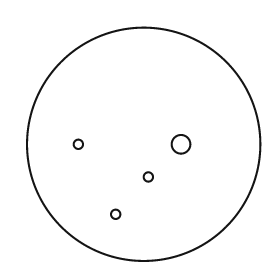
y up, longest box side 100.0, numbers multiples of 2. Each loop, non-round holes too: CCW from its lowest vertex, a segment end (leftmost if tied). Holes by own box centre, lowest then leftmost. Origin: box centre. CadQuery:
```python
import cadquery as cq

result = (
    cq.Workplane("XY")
    .moveTo(0.0, 0.0)
    .circle(50.0)
    .moveTo(-12.0, -30.0)
    .circle(2.0)
    .moveTo(2.0, -14.0)
    .circle(2.0)
    .moveTo(-28.0, 0.0)
    .circle(2.0)
    .moveTo(16.0, 0.0)
    .circle(4.0)
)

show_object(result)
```